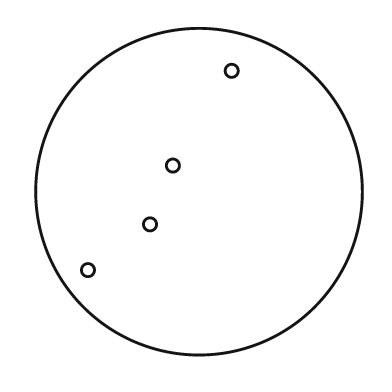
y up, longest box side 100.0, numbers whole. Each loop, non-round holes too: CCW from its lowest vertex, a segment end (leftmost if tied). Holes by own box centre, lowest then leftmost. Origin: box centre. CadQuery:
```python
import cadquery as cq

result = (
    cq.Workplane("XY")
    .moveTo(0.0, 0.0)
    .circle(50.0)
    .moveTo(-34.0, -24.0)
    .circle(2.0)
    .moveTo(-15.0, -10.0)
    .circle(2.0)
    .moveTo(-8.0, 8.0)
    .circle(2.0)
    .moveTo(10.0, 37.0)
    .circle(2.0)
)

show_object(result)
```